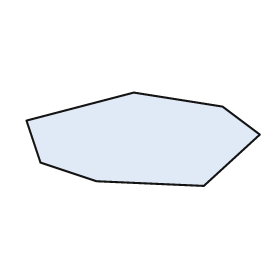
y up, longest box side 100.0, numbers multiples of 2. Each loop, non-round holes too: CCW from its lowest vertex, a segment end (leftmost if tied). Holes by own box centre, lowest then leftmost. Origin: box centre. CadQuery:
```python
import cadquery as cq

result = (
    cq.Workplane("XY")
    .moveTo(26.0, -20.0)
    .lineTo(50.0, 2.0)
    .lineTo(34.0, 14.0)
    .lineTo(-4.0, 20.0)
    .lineTo(-50.0, 8.0)
    .lineTo(-44.0, -10.0)
    .lineTo(-20.0, -18.0)
    .close()
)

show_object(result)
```